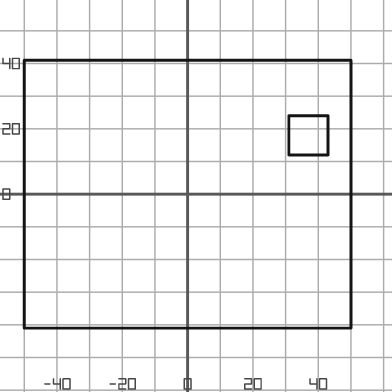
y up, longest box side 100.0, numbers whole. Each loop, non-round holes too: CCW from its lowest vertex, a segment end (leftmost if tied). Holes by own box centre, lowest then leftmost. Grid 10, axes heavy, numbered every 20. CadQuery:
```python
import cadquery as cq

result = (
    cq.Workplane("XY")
    .moveTo(-50.0, -41.0)
    .lineTo(50.0, -41.0)
    .lineTo(50.0, 41.0)
    .lineTo(-50.0, 41.0)
    .close()
    .moveTo(31.0, 12.0)
    .lineTo(43.0, 12.0)
    .lineTo(43.0, 24.0)
    .lineTo(31.0, 24.0)
    .close()
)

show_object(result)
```